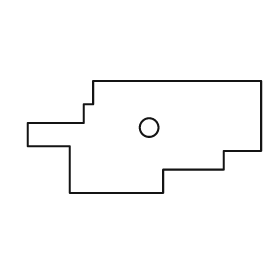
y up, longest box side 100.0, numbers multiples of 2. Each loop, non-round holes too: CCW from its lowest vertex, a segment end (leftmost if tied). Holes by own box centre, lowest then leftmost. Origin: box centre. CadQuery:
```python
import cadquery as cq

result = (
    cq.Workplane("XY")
    .moveTo(-32.0, -24.0)
    .lineTo(8.0, -24.0)
    .lineTo(8.0, -14.0)
    .lineTo(34.0, -14.0)
    .lineTo(34.0, -6.0)
    .lineTo(50.0, -6.0)
    .lineTo(50.0, 24.0)
    .lineTo(-22.0, 24.0)
    .lineTo(-22.0, 14.0)
    .lineTo(-26.0, 14.0)
    .lineTo(-26.0, 6.0)
    .lineTo(-50.0, 6.0)
    .lineTo(-50.0, -4.0)
    .lineTo(-32.0, -4.0)
    .close()
    .moveTo(2.0, 4.0)
    .circle(4.0)
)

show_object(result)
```